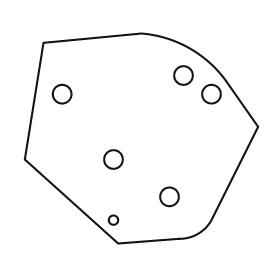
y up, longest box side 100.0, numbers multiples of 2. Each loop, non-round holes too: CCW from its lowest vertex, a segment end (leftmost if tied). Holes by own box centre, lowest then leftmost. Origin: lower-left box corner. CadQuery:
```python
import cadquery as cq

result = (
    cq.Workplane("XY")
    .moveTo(40.0, 0.0)
    .lineTo(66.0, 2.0)
    .threePointArc((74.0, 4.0), (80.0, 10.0))
    .lineTo(100.0, 50.0)
    .lineTo(86.0, 70.0)
    .threePointArc((70.0, 84.0), (50.0, 90.0))
    .lineTo(8.0, 86.0)
    .lineTo(0.0, 36.0)
    .close()
    .moveTo(38.0, 10.0)
    .circle(2.0)
    .moveTo(62.0, 20.0)
    .circle(4.0)
    .moveTo(38.0, 36.0)
    .circle(4.0)
    .moveTo(16.0, 64.0)
    .circle(4.0)
    .moveTo(80.0, 64.0)
    .circle(4.0)
    .moveTo(68.0, 72.0)
    .circle(4.0)
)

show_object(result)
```